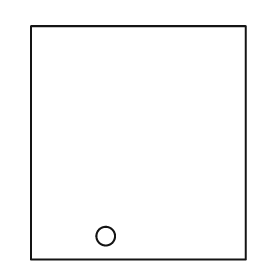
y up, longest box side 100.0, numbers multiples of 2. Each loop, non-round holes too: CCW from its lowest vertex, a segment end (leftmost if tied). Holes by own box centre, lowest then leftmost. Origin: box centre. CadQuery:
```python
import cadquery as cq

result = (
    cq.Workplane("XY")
    .moveTo(-46.0, -50.0)
    .lineTo(46.0, -50.0)
    .lineTo(46.0, 50.0)
    .lineTo(-46.0, 50.0)
    .close()
    .moveTo(-14.0, -40.0)
    .circle(4.0)
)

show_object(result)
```